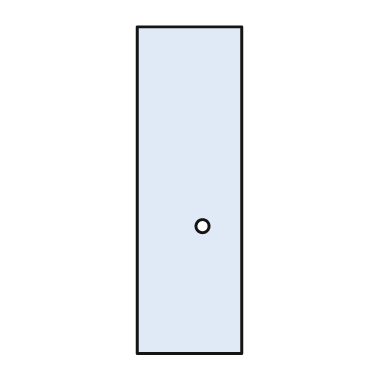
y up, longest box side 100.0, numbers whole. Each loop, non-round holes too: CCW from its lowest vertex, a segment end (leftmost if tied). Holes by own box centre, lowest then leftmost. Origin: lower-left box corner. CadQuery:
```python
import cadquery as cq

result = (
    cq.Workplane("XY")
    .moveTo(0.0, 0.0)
    .lineTo(32.0, 0.0)
    .lineTo(32.0, 100.0)
    .lineTo(0.0, 100.0)
    .close()
    .moveTo(20.0, 39.0)
    .circle(2.0)
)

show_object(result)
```